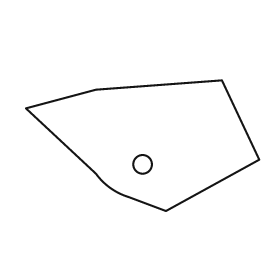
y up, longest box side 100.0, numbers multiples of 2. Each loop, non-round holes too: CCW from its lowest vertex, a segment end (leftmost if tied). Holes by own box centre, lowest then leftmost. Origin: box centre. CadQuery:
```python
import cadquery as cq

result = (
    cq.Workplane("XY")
    .moveTo(10.0, -28.0)
    .lineTo(50.0, -6.0)
    .lineTo(34.0, 28.0)
    .lineTo(-20.0, 24.0)
    .lineTo(-50.0, 16.0)
    .lineTo(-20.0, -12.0)
    .threePointArc((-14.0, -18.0), (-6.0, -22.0))
    .close()
    .moveTo(0.0, -8.0)
    .circle(4.0)
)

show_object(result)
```